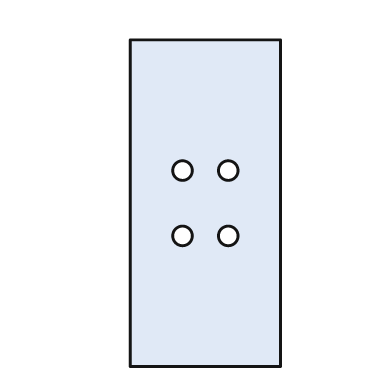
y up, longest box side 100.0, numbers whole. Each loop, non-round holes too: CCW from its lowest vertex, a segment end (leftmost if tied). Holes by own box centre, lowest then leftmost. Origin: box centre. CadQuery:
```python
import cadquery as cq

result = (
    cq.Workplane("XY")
    .moveTo(-23.0, -50.0)
    .lineTo(23.0, -50.0)
    .lineTo(23.0, 50.0)
    .lineTo(-23.0, 50.0)
    .close()
    .moveTo(-7.0, -10.0)
    .circle(3.0)
    .moveTo(7.0, -10.0)
    .circle(3.0)
    .moveTo(-7.0, 10.0)
    .circle(3.0)
    .moveTo(7.0, 10.0)
    .circle(3.0)
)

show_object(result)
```